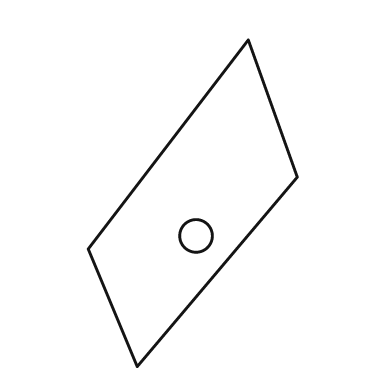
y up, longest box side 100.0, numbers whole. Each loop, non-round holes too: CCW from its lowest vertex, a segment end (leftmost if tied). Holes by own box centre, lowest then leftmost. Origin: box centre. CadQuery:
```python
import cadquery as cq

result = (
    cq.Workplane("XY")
    .moveTo(-17.0, -50.0)
    .lineTo(32.0, 8.0)
    .lineTo(17.0, 50.0)
    .lineTo(-32.0, -14.0)
    .close()
    .moveTo(1.0, -10.0)
    .circle(5.0)
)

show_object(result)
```